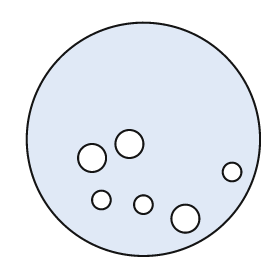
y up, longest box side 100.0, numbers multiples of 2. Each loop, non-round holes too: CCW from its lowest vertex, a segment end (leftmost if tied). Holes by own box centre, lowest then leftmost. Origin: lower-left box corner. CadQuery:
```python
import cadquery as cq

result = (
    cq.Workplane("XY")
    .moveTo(50.0, 50.0)
    .circle(50.0)
    .moveTo(68.0, 16.0)
    .circle(6.0)
    .moveTo(50.0, 22.0)
    .circle(4.0)
    .moveTo(32.0, 24.0)
    .circle(4.0)
    .moveTo(88.0, 36.0)
    .circle(4.0)
    .moveTo(28.0, 42.0)
    .circle(6.0)
    .moveTo(44.0, 48.0)
    .circle(6.0)
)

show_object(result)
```